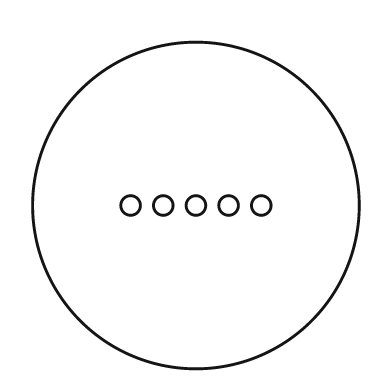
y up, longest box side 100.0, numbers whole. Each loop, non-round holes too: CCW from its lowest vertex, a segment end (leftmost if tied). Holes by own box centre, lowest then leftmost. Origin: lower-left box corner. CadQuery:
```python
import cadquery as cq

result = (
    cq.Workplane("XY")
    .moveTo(50.0, 50.0)
    .circle(50.0)
    .moveTo(30.0, 50.0)
    .circle(3.0)
    .moveTo(40.0, 50.0)
    .circle(3.0)
    .moveTo(50.0, 50.0)
    .circle(3.0)
    .moveTo(60.0, 50.0)
    .circle(3.0)
    .moveTo(70.0, 50.0)
    .circle(3.0)
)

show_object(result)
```